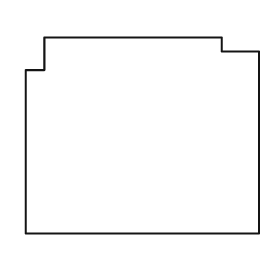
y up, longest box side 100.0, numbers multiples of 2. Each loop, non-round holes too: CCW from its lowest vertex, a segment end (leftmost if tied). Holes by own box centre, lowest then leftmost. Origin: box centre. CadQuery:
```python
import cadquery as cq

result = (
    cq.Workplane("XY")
    .moveTo(-50.0, -42.0)
    .lineTo(50.0, -42.0)
    .lineTo(50.0, 36.0)
    .lineTo(34.0, 36.0)
    .lineTo(34.0, 42.0)
    .lineTo(-42.0, 42.0)
    .lineTo(-42.0, 28.0)
    .lineTo(-50.0, 28.0)
    .close()
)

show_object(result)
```